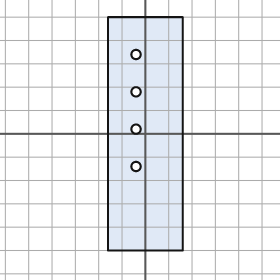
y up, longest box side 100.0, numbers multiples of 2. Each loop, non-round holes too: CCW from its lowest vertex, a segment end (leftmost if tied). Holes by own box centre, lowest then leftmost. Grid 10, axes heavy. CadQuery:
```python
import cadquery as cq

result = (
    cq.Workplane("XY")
    .moveTo(-16.0, -50.0)
    .lineTo(16.0, -50.0)
    .lineTo(16.0, 50.0)
    .lineTo(-16.0, 50.0)
    .close()
    .moveTo(-4.0, -14.0)
    .circle(2.0)
    .moveTo(-4.0, 2.0)
    .circle(2.0)
    .moveTo(-4.0, 18.0)
    .circle(2.0)
    .moveTo(-4.0, 34.0)
    .circle(2.0)
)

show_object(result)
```